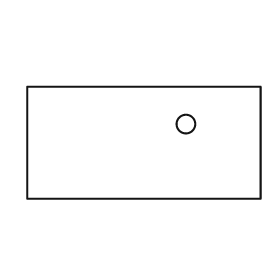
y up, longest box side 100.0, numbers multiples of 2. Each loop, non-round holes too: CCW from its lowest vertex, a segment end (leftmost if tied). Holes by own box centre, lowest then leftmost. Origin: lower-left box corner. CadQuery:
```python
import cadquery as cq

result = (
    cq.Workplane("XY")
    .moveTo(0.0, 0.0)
    .lineTo(100.0, 0.0)
    .lineTo(100.0, 48.0)
    .lineTo(0.0, 48.0)
    .close()
    .moveTo(68.0, 32.0)
    .circle(4.0)
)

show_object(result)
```